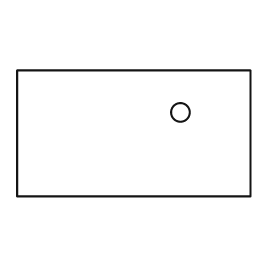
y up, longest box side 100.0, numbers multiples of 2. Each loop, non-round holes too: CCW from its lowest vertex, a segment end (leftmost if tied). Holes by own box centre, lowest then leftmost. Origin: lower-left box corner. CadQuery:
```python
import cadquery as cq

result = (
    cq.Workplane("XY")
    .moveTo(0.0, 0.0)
    .lineTo(100.0, 0.0)
    .lineTo(100.0, 54.0)
    .lineTo(0.0, 54.0)
    .close()
    .moveTo(70.0, 36.0)
    .circle(4.0)
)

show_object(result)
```